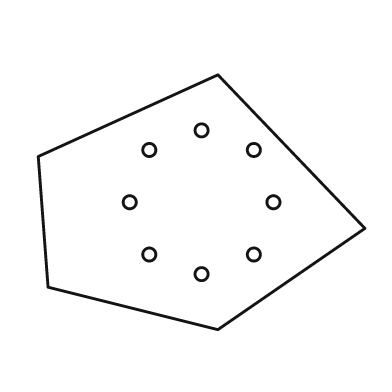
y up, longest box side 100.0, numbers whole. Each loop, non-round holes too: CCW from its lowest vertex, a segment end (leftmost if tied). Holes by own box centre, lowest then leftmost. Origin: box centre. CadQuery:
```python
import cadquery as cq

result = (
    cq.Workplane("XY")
    .moveTo(5.0, -39.0)
    .lineTo(50.0, -8.0)
    .lineTo(5.0, 39.0)
    .lineTo(-50.0, 14.0)
    .lineTo(-47.0, -26.0)
    .close()
    .moveTo(0.0, -22.0)
    .circle(2.0)
    .moveTo(-16.0, -16.0)
    .circle(2.0)
    .moveTo(16.0, -16.0)
    .circle(2.0)
    .moveTo(-22.0, 0.0)
    .circle(2.0)
    .moveTo(22.0, 0.0)
    .circle(2.0)
    .moveTo(-16.0, 16.0)
    .circle(2.0)
    .moveTo(16.0, 16.0)
    .circle(2.0)
    .moveTo(0.0, 22.0)
    .circle(2.0)
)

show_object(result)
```